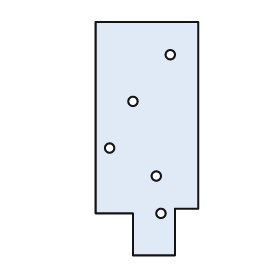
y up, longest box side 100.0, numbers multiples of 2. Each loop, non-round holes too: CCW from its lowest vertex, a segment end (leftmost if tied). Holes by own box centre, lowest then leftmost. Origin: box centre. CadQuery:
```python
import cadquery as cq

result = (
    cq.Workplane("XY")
    .moveTo(-6.0, -50.0)
    .lineTo(12.0, -50.0)
    .lineTo(12.0, -30.0)
    .lineTo(22.0, -30.0)
    .lineTo(22.0, 50.0)
    .lineTo(-22.0, 50.0)
    .lineTo(-22.0, -32.0)
    .lineTo(-6.0, -32.0)
    .close()
    .moveTo(6.0, -32.0)
    .circle(2.0)
    .moveTo(4.0, -16.0)
    .circle(2.0)
    .moveTo(-16.0, -4.0)
    .circle(2.0)
    .moveTo(-6.0, 16.0)
    .circle(2.0)
    .moveTo(10.0, 36.0)
    .circle(2.0)
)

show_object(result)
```